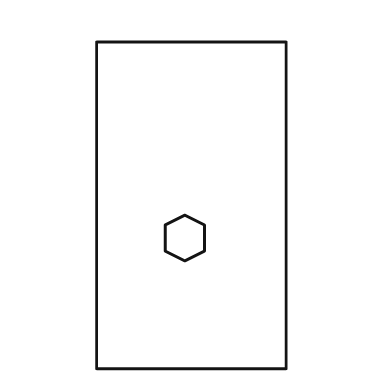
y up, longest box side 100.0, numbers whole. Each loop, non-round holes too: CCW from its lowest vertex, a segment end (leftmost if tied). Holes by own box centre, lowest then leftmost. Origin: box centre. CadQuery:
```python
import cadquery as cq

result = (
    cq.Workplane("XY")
    .moveTo(-29.0, -50.0)
    .lineTo(29.0, -50.0)
    .lineTo(29.0, 50.0)
    .lineTo(-29.0, 50.0)
    .close()
    .moveTo(-2.0, -17.0)
    .lineTo(4.0, -14.0)
    .lineTo(4.0, -6.0)
    .lineTo(-2.0, -3.0)
    .lineTo(-8.0, -6.0)
    .lineTo(-8.0, -14.0)
    .close()
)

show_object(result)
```